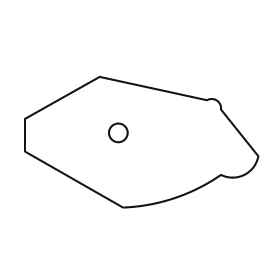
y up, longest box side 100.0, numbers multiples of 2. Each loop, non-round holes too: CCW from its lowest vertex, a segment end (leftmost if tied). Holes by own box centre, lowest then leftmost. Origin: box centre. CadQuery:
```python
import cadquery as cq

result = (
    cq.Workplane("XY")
    .moveTo(-8.0, -28.0)
    .threePointArc((14.0, -24.0), (34.0, -14.0))
    .threePointArc((44.0, -14.0), (50.0, -6.0))
    .lineTo(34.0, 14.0)
    .threePointArc((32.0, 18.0), (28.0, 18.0))
    .lineTo(-18.0, 28.0)
    .lineTo(-50.0, 10.0)
    .lineTo(-50.0, -4.0)
    .close()
    .moveTo(-10.0, 4.0)
    .circle(4.0)
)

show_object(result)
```